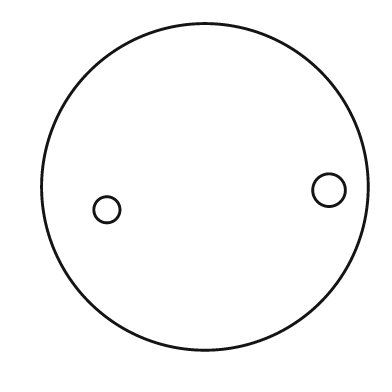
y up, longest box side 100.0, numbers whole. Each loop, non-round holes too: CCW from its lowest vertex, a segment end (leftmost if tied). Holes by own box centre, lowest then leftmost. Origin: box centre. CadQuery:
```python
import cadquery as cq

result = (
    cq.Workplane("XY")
    .moveTo(0.0, 0.0)
    .circle(50.0)
    .moveTo(-30.0, -7.0)
    .circle(4.0)
    .moveTo(38.0, -1.0)
    .circle(5.0)
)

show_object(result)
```